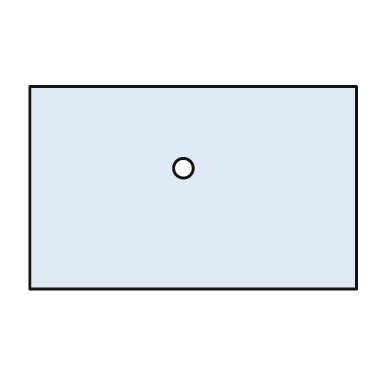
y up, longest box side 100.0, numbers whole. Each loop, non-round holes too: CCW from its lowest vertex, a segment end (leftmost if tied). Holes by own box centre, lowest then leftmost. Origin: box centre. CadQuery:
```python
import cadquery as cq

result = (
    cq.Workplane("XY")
    .moveTo(-50.0, -31.0)
    .lineTo(50.0, -31.0)
    .lineTo(50.0, 31.0)
    .lineTo(-50.0, 31.0)
    .close()
    .moveTo(-3.0, 6.0)
    .circle(3.0)
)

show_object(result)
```